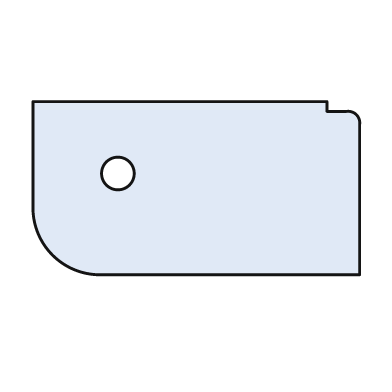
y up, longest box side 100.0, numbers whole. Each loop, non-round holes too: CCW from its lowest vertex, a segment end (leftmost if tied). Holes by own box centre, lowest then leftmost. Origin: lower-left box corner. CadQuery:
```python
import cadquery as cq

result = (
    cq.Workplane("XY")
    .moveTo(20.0, 0.0)
    .lineTo(100.0, 0.0)
    .lineTo(100.0, 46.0)
    .threePointArc((99.0, 49.0), (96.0, 50.0))
    .lineTo(90.0, 50.0)
    .lineTo(90.0, 53.0)
    .lineTo(0.0, 53.0)
    .lineTo(0.0, 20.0)
    .threePointArc((6.0, 6.0), (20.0, 0.0))
    .close()
    .moveTo(26.0, 31.0)
    .circle(5.0)
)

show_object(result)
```